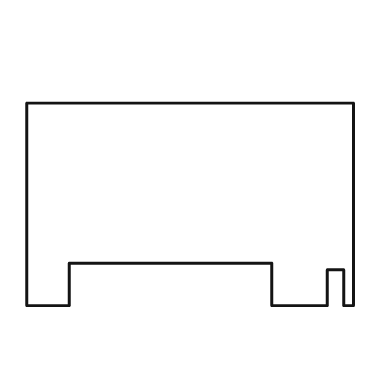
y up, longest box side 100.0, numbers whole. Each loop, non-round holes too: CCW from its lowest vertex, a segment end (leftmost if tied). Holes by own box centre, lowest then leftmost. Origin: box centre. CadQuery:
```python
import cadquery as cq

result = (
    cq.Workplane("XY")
    .moveTo(-50.0, -31.0)
    .lineTo(-37.0, -31.0)
    .lineTo(-37.0, -18.0)
    .lineTo(25.0, -18.0)
    .lineTo(25.0, -31.0)
    .lineTo(42.0, -31.0)
    .lineTo(42.0, -20.0)
    .lineTo(47.0, -20.0)
    .lineTo(47.0, -31.0)
    .lineTo(50.0, -31.0)
    .lineTo(50.0, 31.0)
    .lineTo(-50.0, 31.0)
    .close()
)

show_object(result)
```